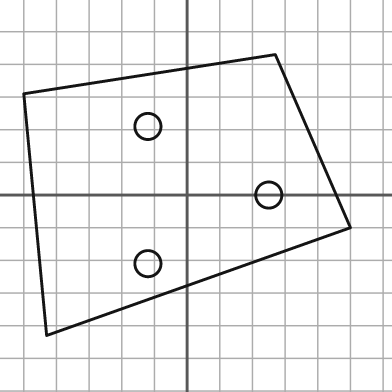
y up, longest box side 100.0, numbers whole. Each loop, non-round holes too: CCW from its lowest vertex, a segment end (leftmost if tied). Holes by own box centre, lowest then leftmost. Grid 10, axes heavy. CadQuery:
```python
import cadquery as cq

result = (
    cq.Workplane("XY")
    .moveTo(-43.0, -43.0)
    .lineTo(50.0, -10.0)
    .lineTo(27.0, 43.0)
    .lineTo(-50.0, 31.0)
    .close()
    .moveTo(-12.0, -21.0)
    .circle(4.0)
    .moveTo(25.0, 0.0)
    .circle(4.0)
    .moveTo(-12.0, 21.0)
    .circle(4.0)
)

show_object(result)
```